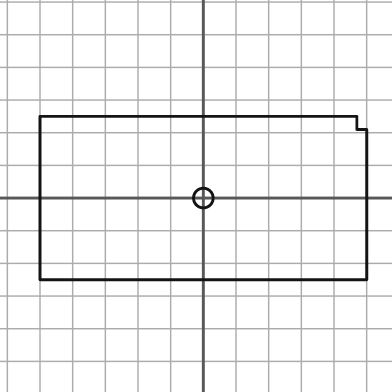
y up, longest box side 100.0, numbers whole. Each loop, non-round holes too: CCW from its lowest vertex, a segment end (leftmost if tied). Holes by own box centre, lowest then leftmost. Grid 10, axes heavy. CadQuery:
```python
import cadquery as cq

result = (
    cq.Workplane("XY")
    .moveTo(-50.0, -25.0)
    .lineTo(50.0, -25.0)
    .lineTo(50.0, 21.0)
    .lineTo(47.0, 21.0)
    .lineTo(47.0, 25.0)
    .lineTo(-50.0, 25.0)
    .close()
    .moveTo(0.0, 0.0)
    .circle(3.0)
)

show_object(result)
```